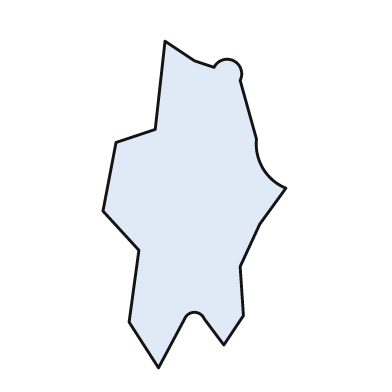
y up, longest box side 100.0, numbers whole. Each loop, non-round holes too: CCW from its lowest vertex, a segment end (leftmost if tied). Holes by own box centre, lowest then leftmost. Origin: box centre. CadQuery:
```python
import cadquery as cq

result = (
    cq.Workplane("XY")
    .moveTo(-11.0, -50.0)
    .lineTo(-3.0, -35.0)
    .threePointArc((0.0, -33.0), (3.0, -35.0))
    .lineTo(9.0, -43.0)
    .lineTo(15.0, -34.0)
    .lineTo(14.0, -19.0)
    .lineTo(20.0, -6.0)
    .lineTo(28.0, 5.0)
    .threePointArc((21.0, 11.0), (19.0, 20.0))
    .lineTo(14.0, 38.0)
    .threePointArc((12.0, 44.0), (6.0, 42.0))
    .lineTo(0.0, 44.0)
    .lineTo(-9.0, 50.0)
    .lineTo(-12.0, 23.0)
    .lineTo(-24.0, 19.0)
    .lineTo(-28.0, -2.0)
    .lineTo(-17.0, -14.0)
    .lineTo(-20.0, -36.0)
    .close()
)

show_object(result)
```